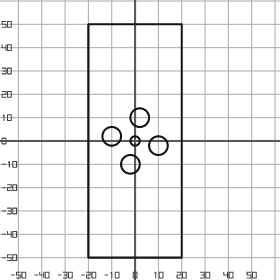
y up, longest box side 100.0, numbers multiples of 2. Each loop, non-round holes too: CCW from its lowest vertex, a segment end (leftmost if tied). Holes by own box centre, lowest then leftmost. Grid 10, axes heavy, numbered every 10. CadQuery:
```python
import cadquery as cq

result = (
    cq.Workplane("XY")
    .moveTo(-20.0, -50.0)
    .lineTo(20.0, -50.0)
    .lineTo(20.0, 50.0)
    .lineTo(-20.0, 50.0)
    .close()
    .moveTo(-2.0, -10.0)
    .circle(4.0)
    .moveTo(10.0, -2.0)
    .circle(4.0)
    .moveTo(0.0, 0.0)
    .circle(2.0)
    .moveTo(-10.0, 2.0)
    .circle(4.0)
    .moveTo(2.0, 10.0)
    .circle(4.0)
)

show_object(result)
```